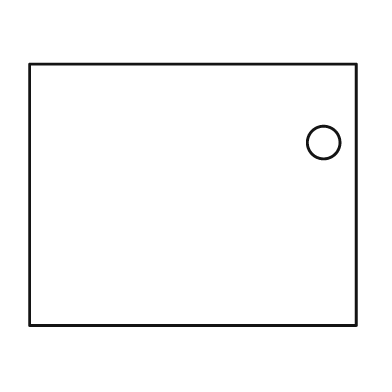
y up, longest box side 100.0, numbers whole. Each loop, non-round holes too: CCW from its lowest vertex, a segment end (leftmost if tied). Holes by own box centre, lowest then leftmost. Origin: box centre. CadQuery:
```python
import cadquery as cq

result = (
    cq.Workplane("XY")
    .moveTo(-50.0, -40.0)
    .lineTo(50.0, -40.0)
    .lineTo(50.0, 40.0)
    .lineTo(-50.0, 40.0)
    .close()
    .moveTo(40.0, 16.0)
    .circle(5.0)
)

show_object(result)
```